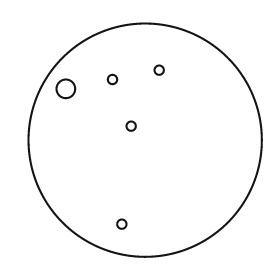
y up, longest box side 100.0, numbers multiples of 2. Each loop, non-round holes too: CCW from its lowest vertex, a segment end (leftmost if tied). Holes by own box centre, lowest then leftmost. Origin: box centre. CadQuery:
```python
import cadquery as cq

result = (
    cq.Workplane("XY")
    .moveTo(0.0, 0.0)
    .circle(50.0)
    .moveTo(-10.0, -36.0)
    .circle(2.0)
    .moveTo(-6.0, 6.0)
    .circle(2.0)
    .moveTo(-34.0, 22.0)
    .circle(4.0)
    .moveTo(-14.0, 26.0)
    .circle(2.0)
    .moveTo(6.0, 30.0)
    .circle(2.0)
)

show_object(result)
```